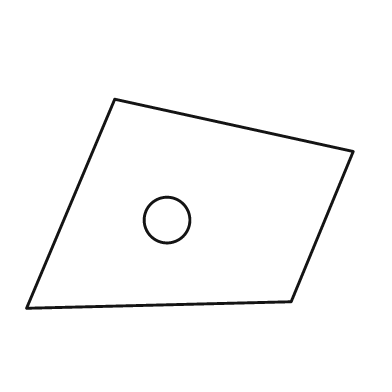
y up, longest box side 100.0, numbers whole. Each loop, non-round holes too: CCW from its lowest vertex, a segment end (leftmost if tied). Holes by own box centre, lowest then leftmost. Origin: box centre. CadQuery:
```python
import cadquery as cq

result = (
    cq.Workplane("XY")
    .moveTo(-50.0, -32.0)
    .lineTo(31.0, -30.0)
    .lineTo(50.0, 16.0)
    .lineTo(-23.0, 32.0)
    .close()
    .moveTo(-7.0, -5.0)
    .circle(7.0)
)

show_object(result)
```